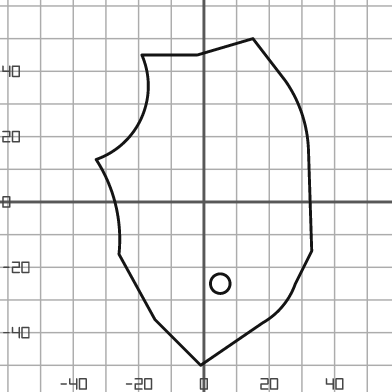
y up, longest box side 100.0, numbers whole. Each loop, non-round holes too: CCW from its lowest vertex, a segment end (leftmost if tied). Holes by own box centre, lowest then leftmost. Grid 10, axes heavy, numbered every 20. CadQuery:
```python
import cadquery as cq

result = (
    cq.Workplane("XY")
    .moveTo(-1.0, -50.0)
    .lineTo(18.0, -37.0)
    .threePointArc((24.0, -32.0), (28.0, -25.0))
    .lineTo(33.0, -15.0)
    .lineTo(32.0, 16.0)
    .threePointArc((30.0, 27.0), (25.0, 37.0))
    .lineTo(15.0, 50.0)
    .lineTo(-2.0, 45.0)
    .lineTo(-19.0, 45.0)
    .threePointArc((-19.0, 26.0), (-33.0, 13.0))
    .threePointArc((-27.0, -1.0), (-26.0, -16.0))
    .lineTo(-15.0, -36.0)
    .close()
    .moveTo(5.0, -25.0)
    .circle(3.0)
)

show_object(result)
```